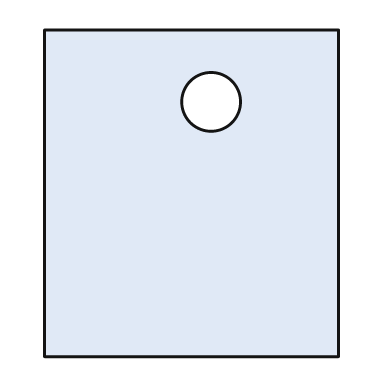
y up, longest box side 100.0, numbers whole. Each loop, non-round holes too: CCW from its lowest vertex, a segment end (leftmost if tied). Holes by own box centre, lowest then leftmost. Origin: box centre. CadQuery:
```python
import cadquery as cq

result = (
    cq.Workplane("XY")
    .moveTo(-45.0, -50.0)
    .lineTo(45.0, -50.0)
    .lineTo(45.0, 50.0)
    .lineTo(-45.0, 50.0)
    .close()
    .moveTo(6.0, 28.0)
    .circle(9.0)
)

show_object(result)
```